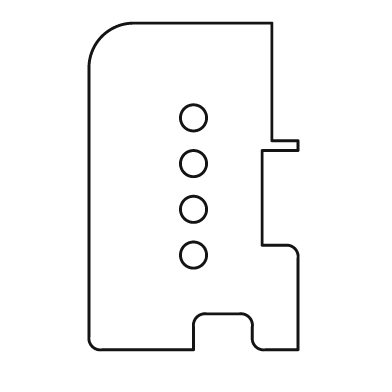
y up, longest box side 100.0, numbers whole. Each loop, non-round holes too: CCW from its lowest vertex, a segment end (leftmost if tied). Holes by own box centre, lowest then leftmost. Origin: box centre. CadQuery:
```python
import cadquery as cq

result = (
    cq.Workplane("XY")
    .moveTo(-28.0, -50.0)
    .lineTo(0.0, -50.0)
    .lineTo(0.0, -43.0)
    .threePointArc((1.0, -40.0), (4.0, -39.0))
    .lineTo(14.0, -39.0)
    .threePointArc((17.0, -40.0), (18.0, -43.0))
    .lineTo(18.0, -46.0)
    .threePointArc((19.0, -49.0), (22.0, -50.0))
    .lineTo(32.0, -50.0)
    .lineTo(32.0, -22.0)
    .threePointArc((31.0, -19.0), (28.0, -18.0))
    .lineTo(21.0, -18.0)
    .lineTo(21.0, 11.0)
    .lineTo(32.0, 11.0)
    .lineTo(32.0, 14.0)
    .lineTo(24.0, 14.0)
    .lineTo(24.0, 50.0)
    .lineTo(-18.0, 50.0)
    .threePointArc((-28.0, 46.0), (-32.0, 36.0))
    .lineTo(-32.0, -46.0)
    .threePointArc((-31.0, -49.0), (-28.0, -50.0))
    .close()
    .moveTo(0.0, -21.0)
    .circle(4.0)
    .moveTo(0.0, -7.0)
    .circle(4.0)
    .moveTo(0.0, 7.0)
    .circle(4.0)
    .moveTo(0.0, 21.0)
    .circle(4.0)
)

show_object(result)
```